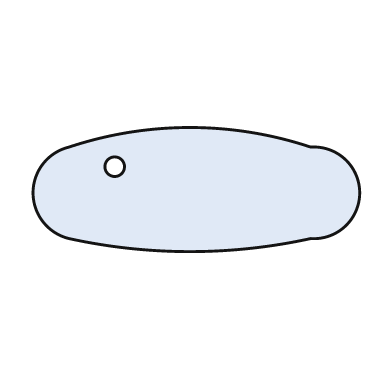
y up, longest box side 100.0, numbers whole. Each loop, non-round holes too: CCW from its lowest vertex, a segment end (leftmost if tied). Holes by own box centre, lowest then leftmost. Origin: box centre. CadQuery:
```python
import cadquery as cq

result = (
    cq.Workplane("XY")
    .moveTo(-39.0, -15.0)
    .threePointArc((-2.0, -19.0), (35.0, -15.0))
    .threePointArc((50.0, -1.0), (35.0, 13.0))
    .threePointArc((-2.0, 19.0), (-39.0, 13.0))
    .threePointArc((-50.0, -1.0), (-39.0, -15.0))
    .close()
    .moveTo(-25.0, 7.0)
    .circle(3.0)
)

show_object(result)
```